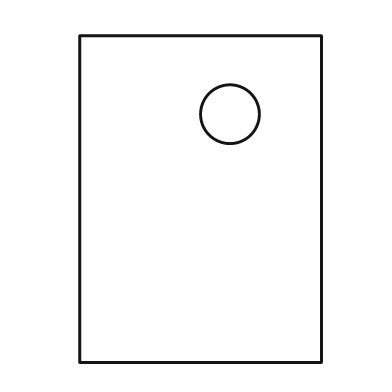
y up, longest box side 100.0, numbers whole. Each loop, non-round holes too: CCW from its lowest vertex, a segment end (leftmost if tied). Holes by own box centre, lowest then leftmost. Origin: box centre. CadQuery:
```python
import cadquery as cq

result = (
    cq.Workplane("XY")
    .moveTo(-37.0, -50.0)
    .lineTo(37.0, -50.0)
    .lineTo(37.0, 50.0)
    .lineTo(-37.0, 50.0)
    .close()
    .moveTo(9.0, 26.0)
    .circle(9.0)
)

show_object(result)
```